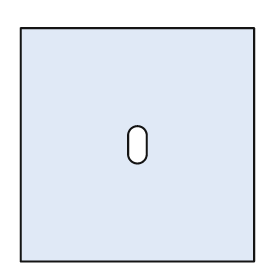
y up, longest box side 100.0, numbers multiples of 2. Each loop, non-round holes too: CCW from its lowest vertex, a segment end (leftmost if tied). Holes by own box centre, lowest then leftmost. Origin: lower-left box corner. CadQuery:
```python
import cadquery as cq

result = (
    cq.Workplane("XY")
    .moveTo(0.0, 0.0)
    .lineTo(100.0, 0.0)
    .lineTo(100.0, 100.0)
    .lineTo(0.0, 100.0)
    .close()
    .moveTo(46.0, 46.0)
    .threePointArc((50.0, 42.0), (54.0, 46.0))
    .lineTo(54.0, 54.0)
    .threePointArc((50.0, 58.0), (46.0, 54.0))
    .close()
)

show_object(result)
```